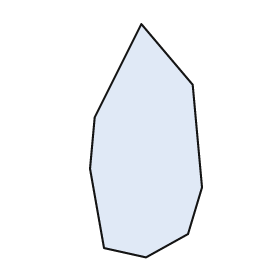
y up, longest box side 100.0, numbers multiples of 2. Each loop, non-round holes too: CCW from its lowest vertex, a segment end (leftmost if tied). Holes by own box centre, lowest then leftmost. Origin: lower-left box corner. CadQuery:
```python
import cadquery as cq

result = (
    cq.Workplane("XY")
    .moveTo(24.0, 0.0)
    .lineTo(42.0, 10.0)
    .lineTo(48.0, 30.0)
    .lineTo(44.0, 74.0)
    .lineTo(22.0, 100.0)
    .lineTo(2.0, 60.0)
    .lineTo(0.0, 38.0)
    .lineTo(6.0, 4.0)
    .close()
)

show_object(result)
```